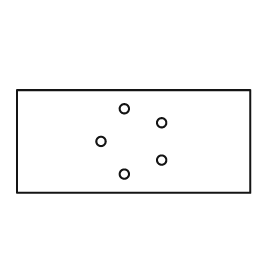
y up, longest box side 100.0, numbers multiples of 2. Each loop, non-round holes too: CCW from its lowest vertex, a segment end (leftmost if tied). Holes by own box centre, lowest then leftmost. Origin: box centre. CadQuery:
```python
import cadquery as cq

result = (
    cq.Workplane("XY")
    .moveTo(-50.0, -22.0)
    .lineTo(50.0, -22.0)
    .lineTo(50.0, 22.0)
    .lineTo(-50.0, 22.0)
    .close()
    .moveTo(-4.0, -14.0)
    .circle(2.0)
    .moveTo(12.0, -8.0)
    .circle(2.0)
    .moveTo(-14.0, 0.0)
    .circle(2.0)
    .moveTo(12.0, 8.0)
    .circle(2.0)
    .moveTo(-4.0, 14.0)
    .circle(2.0)
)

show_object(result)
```